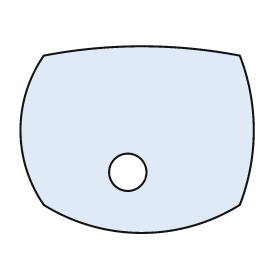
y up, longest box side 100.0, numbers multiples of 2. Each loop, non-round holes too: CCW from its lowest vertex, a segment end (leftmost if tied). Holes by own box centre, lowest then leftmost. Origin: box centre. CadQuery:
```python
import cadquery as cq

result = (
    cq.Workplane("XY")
    .moveTo(-40.0, -28.0)
    .threePointArc((2.0, -40.0), (44.0, -28.0))
    .threePointArc((50.0, 4.0), (44.0, 36.0))
    .threePointArc((2.0, 40.0), (-40.0, 36.0))
    .threePointArc((-50.0, 4.0), (-40.0, -28.0))
    .close()
    .moveTo(-4.0, -14.0)
    .circle(8.0)
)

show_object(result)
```